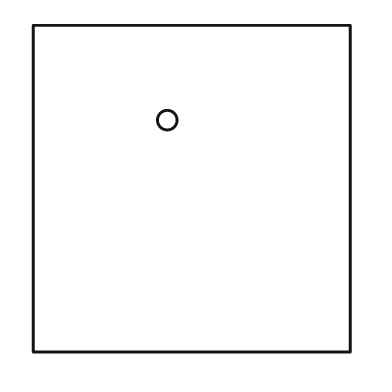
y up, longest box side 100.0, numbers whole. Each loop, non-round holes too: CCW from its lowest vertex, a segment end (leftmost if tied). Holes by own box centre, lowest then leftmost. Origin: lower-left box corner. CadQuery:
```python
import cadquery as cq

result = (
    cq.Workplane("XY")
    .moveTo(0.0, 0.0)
    .lineTo(97.0, 0.0)
    .lineTo(97.0, 100.0)
    .lineTo(0.0, 100.0)
    .close()
    .moveTo(41.0, 71.0)
    .circle(3.0)
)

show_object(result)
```